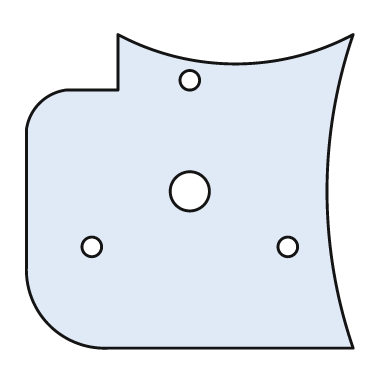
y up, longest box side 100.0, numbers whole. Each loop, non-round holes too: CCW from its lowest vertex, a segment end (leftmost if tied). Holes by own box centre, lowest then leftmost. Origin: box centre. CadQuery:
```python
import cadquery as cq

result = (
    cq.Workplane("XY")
    .moveTo(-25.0, -48.0)
    .lineTo(50.0, -48.0)
    .threePointArc((42.0, 0.0), (50.0, 48.0))
    .threePointArc((14.0, 39.0), (-22.0, 48.0))
    .lineTo(-22.0, 31.0)
    .lineTo(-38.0, 31.0)
    .threePointArc((-46.0, 27.0), (-50.0, 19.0))
    .lineTo(-50.0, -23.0)
    .threePointArc((-43.0, -41.0), (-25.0, -48.0))
    .close()
    .moveTo(-30.0, -17.0)
    .circle(3.0)
    .moveTo(30.0, -17.0)
    .circle(3.0)
    .moveTo(0.0, 0.0)
    .circle(6.0)
    .moveTo(0.0, 34.0)
    .circle(3.0)
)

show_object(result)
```